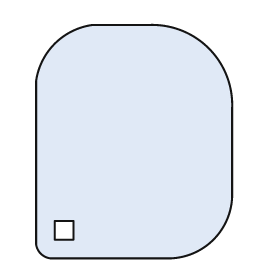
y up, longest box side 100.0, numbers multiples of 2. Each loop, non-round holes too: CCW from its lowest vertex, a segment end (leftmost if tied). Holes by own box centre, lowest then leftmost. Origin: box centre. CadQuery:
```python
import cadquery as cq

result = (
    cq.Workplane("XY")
    .moveTo(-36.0, -50.0)
    .lineTo(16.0, -50.0)
    .threePointArc((34.0, -42.0), (42.0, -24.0))
    .lineTo(42.0, 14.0)
    .threePointArc((32.0, 40.0), (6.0, 50.0))
    .lineTo(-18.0, 50.0)
    .threePointArc((-34.0, 42.0), (-42.0, 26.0))
    .lineTo(-42.0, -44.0)
    .threePointArc((-40.0, -48.0), (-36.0, -50.0))
    .close()
    .moveTo(-34.0, -42.0)
    .lineTo(-26.0, -42.0)
    .lineTo(-26.0, -34.0)
    .lineTo(-34.0, -34.0)
    .close()
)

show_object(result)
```